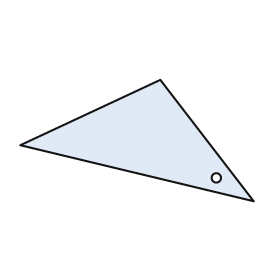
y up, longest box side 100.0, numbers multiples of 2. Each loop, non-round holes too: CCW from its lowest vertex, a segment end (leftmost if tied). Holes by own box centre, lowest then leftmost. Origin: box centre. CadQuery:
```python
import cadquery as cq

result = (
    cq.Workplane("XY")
    .moveTo(50.0, -26.0)
    .lineTo(10.0, 26.0)
    .lineTo(-50.0, -2.0)
    .close()
    .moveTo(34.0, -16.0)
    .circle(2.0)
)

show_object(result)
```